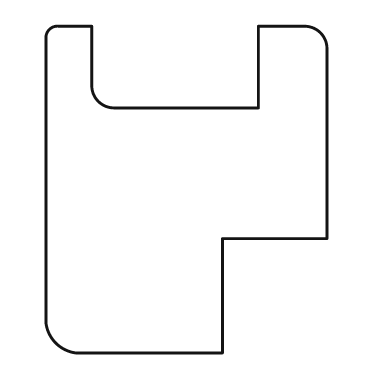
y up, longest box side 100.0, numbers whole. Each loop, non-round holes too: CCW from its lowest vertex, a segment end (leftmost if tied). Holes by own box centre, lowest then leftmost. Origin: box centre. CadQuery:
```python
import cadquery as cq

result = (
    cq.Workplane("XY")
    .moveTo(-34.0, -50.0)
    .lineTo(11.0, -50.0)
    .lineTo(11.0, -15.0)
    .lineTo(43.0, -15.0)
    .lineTo(43.0, 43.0)
    .threePointArc((41.0, 48.0), (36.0, 50.0))
    .lineTo(22.0, 50.0)
    .lineTo(22.0, 25.0)
    .lineTo(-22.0, 25.0)
    .threePointArc((-27.0, 27.0), (-29.0, 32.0))
    .lineTo(-29.0, 50.0)
    .lineTo(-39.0, 50.0)
    .threePointArc((-42.0, 49.0), (-43.0, 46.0))
    .lineTo(-43.0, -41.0)
    .threePointArc((-40.0, -47.0), (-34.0, -50.0))
    .close()
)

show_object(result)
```